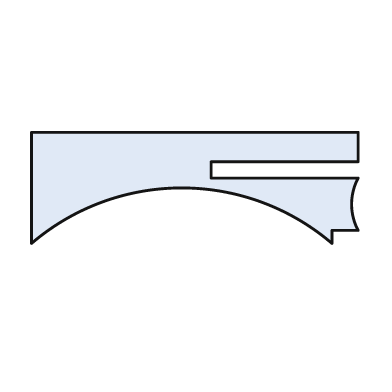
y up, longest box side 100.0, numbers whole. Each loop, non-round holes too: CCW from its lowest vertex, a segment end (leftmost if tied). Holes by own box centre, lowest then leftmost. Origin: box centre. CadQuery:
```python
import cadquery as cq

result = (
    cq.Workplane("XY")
    .moveTo(-50.0, -17.0)
    .threePointArc((-4.0, 0.0), (42.0, -17.0))
    .lineTo(42.0, -13.0)
    .lineTo(50.0, -13.0)
    .threePointArc((48.0, -5.0), (50.0, 3.0))
    .lineTo(5.0, 3.0)
    .lineTo(5.0, 8.0)
    .lineTo(50.0, 8.0)
    .lineTo(50.0, 17.0)
    .lineTo(-50.0, 17.0)
    .close()
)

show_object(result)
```